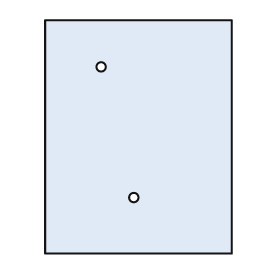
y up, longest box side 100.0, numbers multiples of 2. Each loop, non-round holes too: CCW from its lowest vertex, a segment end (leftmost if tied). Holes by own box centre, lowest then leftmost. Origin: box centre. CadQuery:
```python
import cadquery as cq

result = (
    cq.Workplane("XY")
    .moveTo(-40.0, -50.0)
    .lineTo(40.0, -50.0)
    .lineTo(40.0, 50.0)
    .lineTo(-40.0, 50.0)
    .close()
    .moveTo(-2.0, -26.0)
    .circle(2.0)
    .moveTo(-16.0, 30.0)
    .circle(2.0)
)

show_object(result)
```